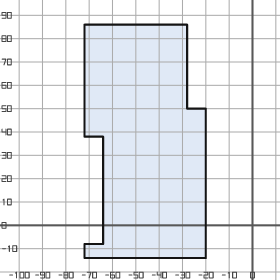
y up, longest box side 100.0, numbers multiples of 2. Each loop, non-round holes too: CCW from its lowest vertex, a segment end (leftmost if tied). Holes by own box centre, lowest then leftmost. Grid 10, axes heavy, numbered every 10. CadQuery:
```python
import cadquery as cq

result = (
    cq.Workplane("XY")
    .moveTo(-72.0, -14.0)
    .lineTo(-20.0, -14.0)
    .lineTo(-20.0, 50.0)
    .lineTo(-28.0, 50.0)
    .lineTo(-28.0, 86.0)
    .lineTo(-72.0, 86.0)
    .lineTo(-72.0, 38.0)
    .lineTo(-64.0, 38.0)
    .lineTo(-64.0, -8.0)
    .lineTo(-72.0, -8.0)
    .close()
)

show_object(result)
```